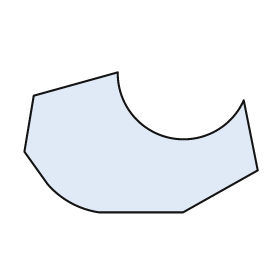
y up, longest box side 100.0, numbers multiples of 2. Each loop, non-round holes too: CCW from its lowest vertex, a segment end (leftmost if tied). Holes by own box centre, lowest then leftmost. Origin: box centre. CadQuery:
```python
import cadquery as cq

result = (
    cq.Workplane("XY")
    .moveTo(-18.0, -30.0)
    .lineTo(18.0, -30.0)
    .lineTo(50.0, -12.0)
    .lineTo(44.0, 18.0)
    .threePointArc((12.0, 2.0), (-10.0, 30.0))
    .lineTo(-46.0, 20.0)
    .lineTo(-50.0, -4.0)
    .lineTo(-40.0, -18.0)
    .threePointArc((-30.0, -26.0), (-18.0, -30.0))
    .close()
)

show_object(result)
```